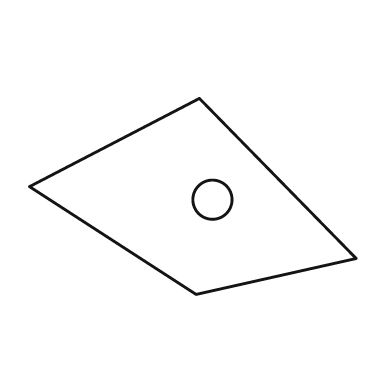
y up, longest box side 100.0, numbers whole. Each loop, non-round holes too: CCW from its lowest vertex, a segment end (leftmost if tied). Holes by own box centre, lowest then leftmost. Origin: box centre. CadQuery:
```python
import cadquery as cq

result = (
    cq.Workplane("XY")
    .moveTo(1.0, -30.0)
    .lineTo(50.0, -19.0)
    .lineTo(2.0, 30.0)
    .lineTo(-50.0, 3.0)
    .close()
    .moveTo(6.0, -1.0)
    .circle(6.0)
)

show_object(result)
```